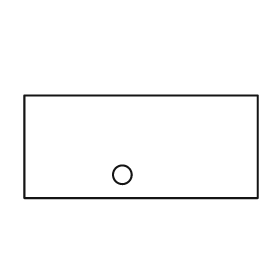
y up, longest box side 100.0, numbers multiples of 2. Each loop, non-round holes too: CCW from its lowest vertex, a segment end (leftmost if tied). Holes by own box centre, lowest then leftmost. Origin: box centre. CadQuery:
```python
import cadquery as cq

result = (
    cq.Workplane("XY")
    .moveTo(-50.0, -22.0)
    .lineTo(50.0, -22.0)
    .lineTo(50.0, 22.0)
    .lineTo(-50.0, 22.0)
    .close()
    .moveTo(-8.0, -12.0)
    .circle(4.0)
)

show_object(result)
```